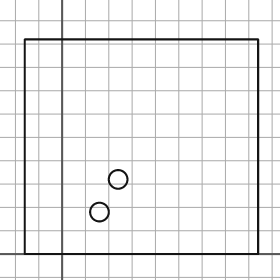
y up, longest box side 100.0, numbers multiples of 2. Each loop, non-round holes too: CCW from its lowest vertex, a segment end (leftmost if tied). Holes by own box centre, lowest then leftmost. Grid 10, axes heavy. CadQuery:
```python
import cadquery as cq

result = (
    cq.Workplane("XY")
    .moveTo(-16.0, 0.0)
    .lineTo(84.0, 0.0)
    .lineTo(84.0, 92.0)
    .lineTo(-16.0, 92.0)
    .close()
    .moveTo(16.0, 18.0)
    .circle(4.0)
    .moveTo(24.0, 32.0)
    .circle(4.0)
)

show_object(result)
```